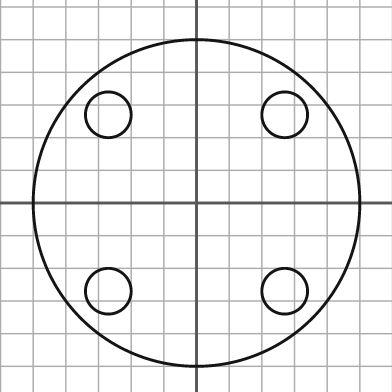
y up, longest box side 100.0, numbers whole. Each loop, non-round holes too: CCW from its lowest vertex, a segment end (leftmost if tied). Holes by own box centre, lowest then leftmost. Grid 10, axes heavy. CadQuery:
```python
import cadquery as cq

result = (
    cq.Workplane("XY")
    .moveTo(0.0, 0.0)
    .circle(50.0)
    .moveTo(-27.0, -27.0)
    .circle(7.0)
    .moveTo(27.0, -27.0)
    .circle(7.0)
    .moveTo(-27.0, 27.0)
    .circle(7.0)
    .moveTo(27.0, 27.0)
    .circle(7.0)
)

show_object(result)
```